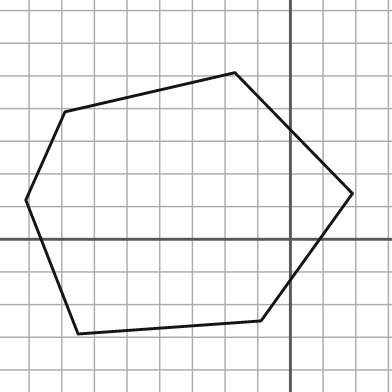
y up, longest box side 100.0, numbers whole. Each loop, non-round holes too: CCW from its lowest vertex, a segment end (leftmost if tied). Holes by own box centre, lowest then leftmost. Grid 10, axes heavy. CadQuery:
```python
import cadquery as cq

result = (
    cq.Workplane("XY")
    .moveTo(-65.0, -29.0)
    .lineTo(-9.0, -25.0)
    .lineTo(19.0, 14.0)
    .lineTo(-17.0, 51.0)
    .lineTo(-69.0, 39.0)
    .lineTo(-81.0, 12.0)
    .close()
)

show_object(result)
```